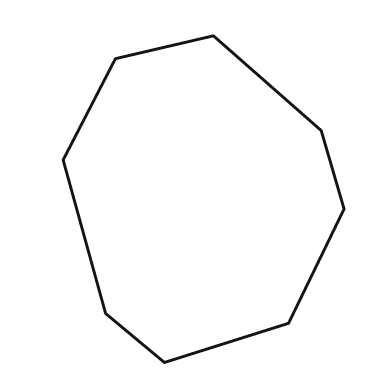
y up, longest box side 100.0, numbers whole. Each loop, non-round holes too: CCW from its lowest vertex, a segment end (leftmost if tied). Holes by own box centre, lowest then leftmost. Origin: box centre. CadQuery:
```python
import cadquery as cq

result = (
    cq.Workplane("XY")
    .moveTo(-12.0, -50.0)
    .lineTo(26.0, -38.0)
    .lineTo(43.0, -3.0)
    .lineTo(36.0, 21.0)
    .lineTo(3.0, 50.0)
    .lineTo(-27.0, 43.0)
    .lineTo(-43.0, 12.0)
    .lineTo(-30.0, -35.0)
    .close()
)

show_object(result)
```